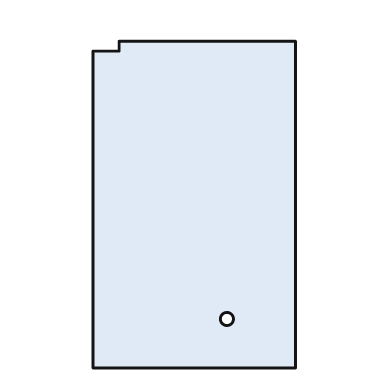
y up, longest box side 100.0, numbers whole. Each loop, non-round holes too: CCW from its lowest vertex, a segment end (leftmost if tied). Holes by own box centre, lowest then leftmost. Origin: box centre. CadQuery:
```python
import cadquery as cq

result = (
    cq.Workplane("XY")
    .moveTo(-31.0, -50.0)
    .lineTo(31.0, -50.0)
    .lineTo(31.0, 50.0)
    .lineTo(-23.0, 50.0)
    .lineTo(-23.0, 47.0)
    .lineTo(-31.0, 47.0)
    .close()
    .moveTo(10.0, -35.0)
    .circle(2.0)
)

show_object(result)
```